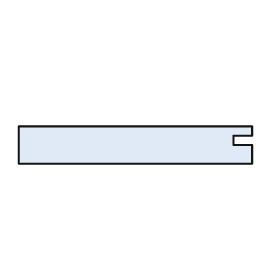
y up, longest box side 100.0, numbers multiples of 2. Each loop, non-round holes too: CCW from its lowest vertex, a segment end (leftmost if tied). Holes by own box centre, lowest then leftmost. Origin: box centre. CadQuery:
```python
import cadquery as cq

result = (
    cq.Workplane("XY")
    .moveTo(-50.0, -8.0)
    .lineTo(50.0, -8.0)
    .lineTo(50.0, 0.0)
    .lineTo(42.0, 0.0)
    .lineTo(42.0, 4.0)
    .lineTo(50.0, 4.0)
    .lineTo(50.0, 8.0)
    .lineTo(-50.0, 8.0)
    .close()
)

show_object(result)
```